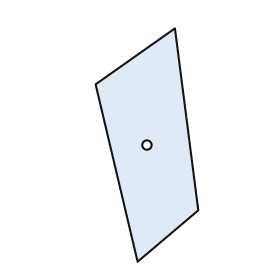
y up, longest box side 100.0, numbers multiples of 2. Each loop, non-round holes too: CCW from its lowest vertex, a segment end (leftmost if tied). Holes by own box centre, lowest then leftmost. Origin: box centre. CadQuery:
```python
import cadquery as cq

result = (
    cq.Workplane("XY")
    .moveTo(-4.0, -50.0)
    .lineTo(22.0, -28.0)
    .lineTo(12.0, 50.0)
    .lineTo(-22.0, 26.0)
    .close()
    .moveTo(0.0, 0.0)
    .circle(2.0)
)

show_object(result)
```